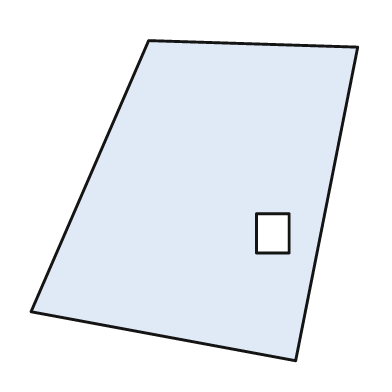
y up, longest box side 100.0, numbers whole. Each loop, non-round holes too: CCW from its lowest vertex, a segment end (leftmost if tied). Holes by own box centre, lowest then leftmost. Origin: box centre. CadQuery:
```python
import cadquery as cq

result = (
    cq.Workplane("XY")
    .moveTo(31.0, -49.0)
    .lineTo(50.0, 47.0)
    .lineTo(-14.0, 49.0)
    .lineTo(-50.0, -34.0)
    .close()
    .moveTo(19.0, -16.0)
    .lineTo(29.0, -16.0)
    .lineTo(29.0, -4.0)
    .lineTo(19.0, -4.0)
    .close()
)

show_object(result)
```